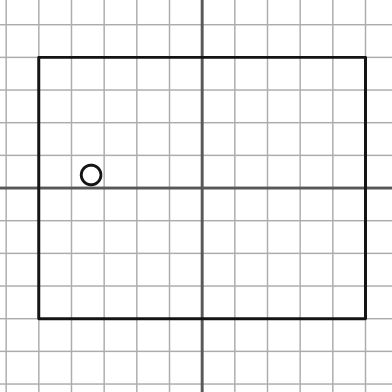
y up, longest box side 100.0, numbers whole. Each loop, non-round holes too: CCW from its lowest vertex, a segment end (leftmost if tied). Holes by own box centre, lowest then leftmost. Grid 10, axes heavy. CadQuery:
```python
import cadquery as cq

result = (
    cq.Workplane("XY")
    .moveTo(-50.0, -40.0)
    .lineTo(50.0, -40.0)
    .lineTo(50.0, 40.0)
    .lineTo(-50.0, 40.0)
    .close()
    .moveTo(-34.0, 4.0)
    .circle(3.0)
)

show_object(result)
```